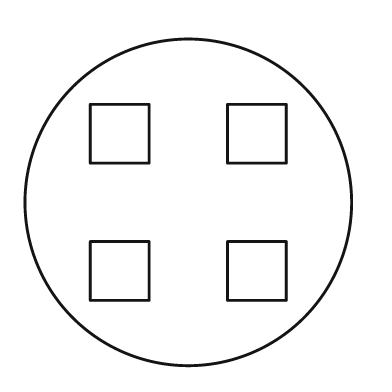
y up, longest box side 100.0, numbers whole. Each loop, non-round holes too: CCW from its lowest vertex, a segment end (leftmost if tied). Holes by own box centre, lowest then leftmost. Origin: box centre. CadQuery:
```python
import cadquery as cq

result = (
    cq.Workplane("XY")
    .moveTo(0.0, 0.0)
    .circle(50.0)
    .moveTo(-30.0, -30.0)
    .lineTo(-12.0, -30.0)
    .lineTo(-12.0, -12.0)
    .lineTo(-30.0, -12.0)
    .close()
    .moveTo(12.0, -30.0)
    .lineTo(30.0, -30.0)
    .lineTo(30.0, -12.0)
    .lineTo(12.0, -12.0)
    .close()
    .moveTo(-30.0, 12.0)
    .lineTo(-12.0, 12.0)
    .lineTo(-12.0, 30.0)
    .lineTo(-30.0, 30.0)
    .close()
    .moveTo(12.0, 12.0)
    .lineTo(30.0, 12.0)
    .lineTo(30.0, 30.0)
    .lineTo(12.0, 30.0)
    .close()
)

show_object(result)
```